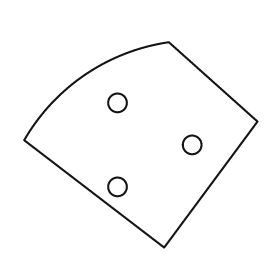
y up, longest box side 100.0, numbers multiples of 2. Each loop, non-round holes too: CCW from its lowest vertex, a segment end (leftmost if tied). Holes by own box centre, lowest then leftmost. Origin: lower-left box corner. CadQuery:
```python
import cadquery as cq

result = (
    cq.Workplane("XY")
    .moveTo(60.0, 0.0)
    .lineTo(100.0, 54.0)
    .lineTo(62.0, 88.0)
    .threePointArc((26.0, 74.0), (0.0, 46.0))
    .close()
    .moveTo(40.0, 26.0)
    .circle(4.0)
    .moveTo(72.0, 44.0)
    .circle(4.0)
    .moveTo(40.0, 62.0)
    .circle(4.0)
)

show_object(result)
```